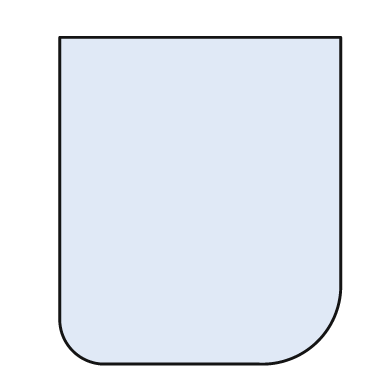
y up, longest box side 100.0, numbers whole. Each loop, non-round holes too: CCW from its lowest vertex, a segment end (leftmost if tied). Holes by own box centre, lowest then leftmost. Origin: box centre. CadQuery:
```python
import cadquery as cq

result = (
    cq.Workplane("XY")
    .moveTo(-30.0, -50.0)
    .lineTo(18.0, -50.0)
    .threePointArc((36.0, -43.0), (43.0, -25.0))
    .lineTo(43.0, 50.0)
    .lineTo(-43.0, 50.0)
    .lineTo(-43.0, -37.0)
    .threePointArc((-39.0, -46.0), (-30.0, -50.0))
    .close()
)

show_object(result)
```